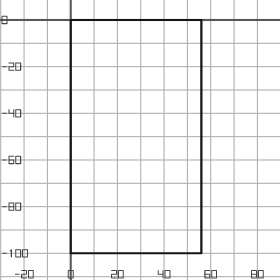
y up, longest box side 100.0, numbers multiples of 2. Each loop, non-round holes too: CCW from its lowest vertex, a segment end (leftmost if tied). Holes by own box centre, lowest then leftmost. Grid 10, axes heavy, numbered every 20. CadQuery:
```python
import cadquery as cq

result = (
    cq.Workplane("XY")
    .moveTo(0.0, -100.0)
    .lineTo(56.0, -100.0)
    .lineTo(56.0, 0.0)
    .lineTo(0.0, 0.0)
    .close()
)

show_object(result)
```